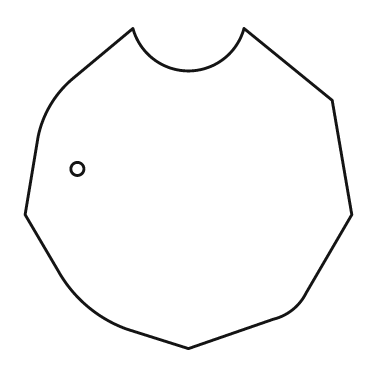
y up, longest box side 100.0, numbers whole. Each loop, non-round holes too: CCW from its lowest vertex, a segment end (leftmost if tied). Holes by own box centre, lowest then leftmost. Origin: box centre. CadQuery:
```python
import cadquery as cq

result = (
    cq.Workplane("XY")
    .moveTo(0.0, -49.0)
    .lineTo(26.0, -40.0)
    .threePointArc((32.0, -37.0), (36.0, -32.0))
    .lineTo(50.0, -8.0)
    .lineTo(44.0, 27.0)
    .lineTo(17.0, 49.0)
    .threePointArc((0.0, 36.0), (-17.0, 49.0))
    .lineTo(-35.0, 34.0)
    .threePointArc((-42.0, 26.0), (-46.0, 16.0))
    .lineTo(-50.0, -8.0)
    .lineTo(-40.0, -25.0)
    .threePointArc((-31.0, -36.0), (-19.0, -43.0))
    .close()
    .moveTo(-34.0, 6.0)
    .circle(2.0)
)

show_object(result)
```